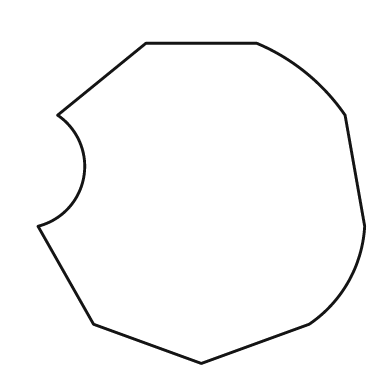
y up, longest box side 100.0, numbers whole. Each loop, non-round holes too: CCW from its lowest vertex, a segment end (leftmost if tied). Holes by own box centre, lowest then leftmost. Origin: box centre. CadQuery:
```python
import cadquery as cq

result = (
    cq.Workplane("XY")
    .moveTo(0.0, -49.0)
    .lineTo(33.0, -37.0)
    .threePointArc((45.0, -24.0), (50.0, -7.0))
    .lineTo(44.0, 27.0)
    .threePointArc((32.0, 40.0), (17.0, 49.0))
    .lineTo(-17.0, 49.0)
    .lineTo(-44.0, 27.0)
    .threePointArc((-36.0, 8.0), (-50.0, -7.0))
    .lineTo(-33.0, -37.0)
    .close()
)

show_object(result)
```